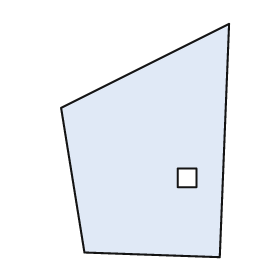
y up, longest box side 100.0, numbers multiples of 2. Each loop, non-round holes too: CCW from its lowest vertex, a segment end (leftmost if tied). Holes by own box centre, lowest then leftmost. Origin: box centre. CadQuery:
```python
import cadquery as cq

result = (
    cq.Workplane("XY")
    .moveTo(32.0, -50.0)
    .lineTo(36.0, 50.0)
    .lineTo(-36.0, 14.0)
    .lineTo(-26.0, -48.0)
    .close()
    .moveTo(14.0, -20.0)
    .lineTo(22.0, -20.0)
    .lineTo(22.0, -12.0)
    .lineTo(14.0, -12.0)
    .close()
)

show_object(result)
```